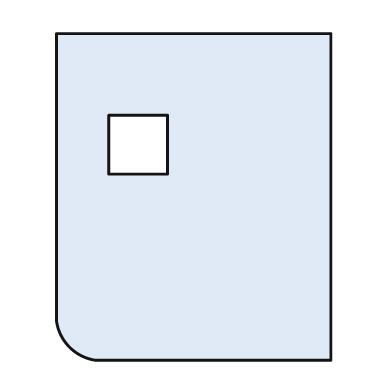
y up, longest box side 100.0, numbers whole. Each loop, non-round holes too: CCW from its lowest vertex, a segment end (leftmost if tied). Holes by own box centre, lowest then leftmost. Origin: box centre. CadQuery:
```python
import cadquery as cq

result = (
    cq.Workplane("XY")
    .moveTo(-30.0, -50.0)
    .lineTo(42.0, -50.0)
    .lineTo(42.0, 50.0)
    .lineTo(-42.0, 50.0)
    .lineTo(-42.0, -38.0)
    .threePointArc((-38.0, -46.0), (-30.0, -50.0))
    .close()
    .moveTo(-26.0, 7.0)
    .lineTo(-8.0, 7.0)
    .lineTo(-8.0, 25.0)
    .lineTo(-26.0, 25.0)
    .close()
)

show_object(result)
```